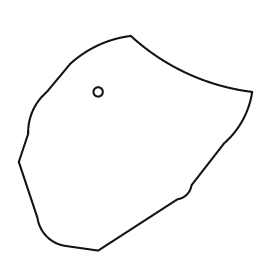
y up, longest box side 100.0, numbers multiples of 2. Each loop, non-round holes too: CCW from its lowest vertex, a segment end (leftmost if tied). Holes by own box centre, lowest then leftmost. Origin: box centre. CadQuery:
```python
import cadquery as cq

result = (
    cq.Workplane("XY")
    .moveTo(-16.0, -46.0)
    .lineTo(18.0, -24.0)
    .threePointArc((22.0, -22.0), (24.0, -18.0))
    .lineTo(38.0, 0.0)
    .threePointArc((46.0, 10.0), (50.0, 22.0))
    .threePointArc((22.0, 30.0), (-2.0, 46.0))
    .threePointArc((-16.0, 42.0), (-28.0, 34.0))
    .lineTo(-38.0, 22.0)
    .threePointArc((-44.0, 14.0), (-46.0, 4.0))
    .lineTo(-50.0, -8.0)
    .lineTo(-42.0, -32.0)
    .threePointArc((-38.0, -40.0), (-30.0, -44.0))
    .close()
    .moveTo(-16.0, 22.0)
    .circle(2.0)
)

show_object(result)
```